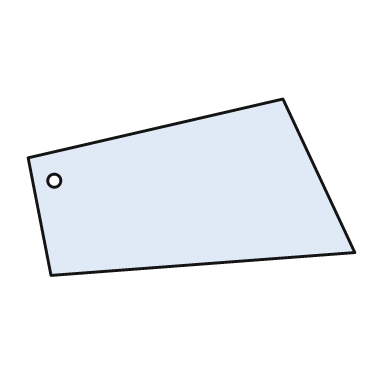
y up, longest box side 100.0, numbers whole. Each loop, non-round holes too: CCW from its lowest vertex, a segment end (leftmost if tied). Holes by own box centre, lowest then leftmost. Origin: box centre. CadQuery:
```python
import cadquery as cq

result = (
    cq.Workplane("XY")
    .moveTo(-43.0, -27.0)
    .lineTo(50.0, -20.0)
    .lineTo(28.0, 27.0)
    .lineTo(-50.0, 9.0)
    .close()
    .moveTo(-42.0, 2.0)
    .circle(2.0)
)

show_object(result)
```